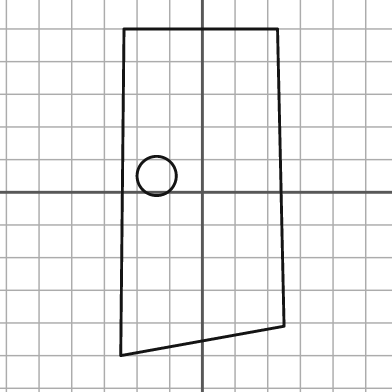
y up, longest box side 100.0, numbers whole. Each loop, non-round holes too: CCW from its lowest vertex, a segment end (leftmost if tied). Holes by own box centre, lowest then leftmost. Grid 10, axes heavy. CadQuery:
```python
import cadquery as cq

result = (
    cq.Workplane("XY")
    .moveTo(-25.0, -50.0)
    .lineTo(25.0, -41.0)
    .lineTo(23.0, 50.0)
    .lineTo(-24.0, 50.0)
    .close()
    .moveTo(-14.0, 5.0)
    .circle(6.0)
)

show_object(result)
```